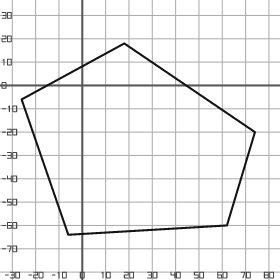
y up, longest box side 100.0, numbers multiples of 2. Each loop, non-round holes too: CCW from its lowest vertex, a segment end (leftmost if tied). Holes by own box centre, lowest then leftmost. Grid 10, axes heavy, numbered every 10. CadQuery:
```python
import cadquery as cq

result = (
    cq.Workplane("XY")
    .moveTo(-6.0, -64.0)
    .lineTo(62.0, -60.0)
    .lineTo(74.0, -20.0)
    .lineTo(18.0, 18.0)
    .lineTo(-26.0, -6.0)
    .close()
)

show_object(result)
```